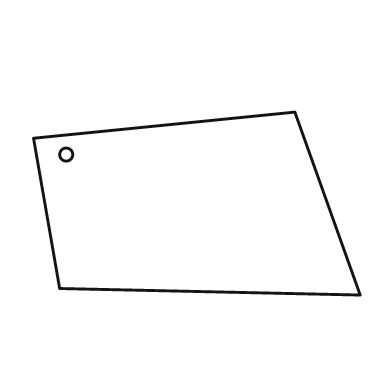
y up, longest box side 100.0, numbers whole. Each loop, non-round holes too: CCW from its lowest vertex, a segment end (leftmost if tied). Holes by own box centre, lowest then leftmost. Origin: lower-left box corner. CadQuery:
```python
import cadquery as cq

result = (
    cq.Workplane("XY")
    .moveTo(100.0, 0.0)
    .lineTo(80.0, 56.0)
    .lineTo(0.0, 48.0)
    .lineTo(8.0, 2.0)
    .close()
    .moveTo(10.0, 43.0)
    .circle(2.0)
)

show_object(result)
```